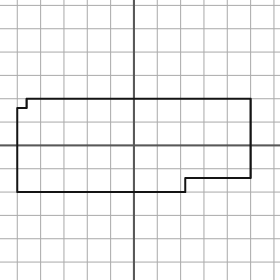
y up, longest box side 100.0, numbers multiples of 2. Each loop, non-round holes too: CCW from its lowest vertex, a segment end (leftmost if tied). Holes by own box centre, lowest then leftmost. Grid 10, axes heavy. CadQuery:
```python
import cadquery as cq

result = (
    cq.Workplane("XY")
    .moveTo(-50.0, -20.0)
    .lineTo(22.0, -20.0)
    .lineTo(22.0, -14.0)
    .lineTo(50.0, -14.0)
    .lineTo(50.0, 20.0)
    .lineTo(-46.0, 20.0)
    .lineTo(-46.0, 16.0)
    .lineTo(-50.0, 16.0)
    .close()
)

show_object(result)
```